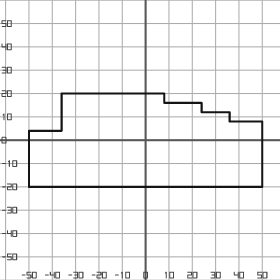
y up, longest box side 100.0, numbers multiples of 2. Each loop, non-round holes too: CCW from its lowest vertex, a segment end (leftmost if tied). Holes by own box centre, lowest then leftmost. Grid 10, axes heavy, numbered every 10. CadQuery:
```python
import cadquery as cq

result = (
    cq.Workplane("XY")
    .moveTo(-50.0, -20.0)
    .lineTo(50.0, -20.0)
    .lineTo(50.0, 8.0)
    .lineTo(36.0, 8.0)
    .lineTo(36.0, 12.0)
    .lineTo(24.0, 12.0)
    .lineTo(24.0, 16.0)
    .lineTo(8.0, 16.0)
    .lineTo(8.0, 20.0)
    .lineTo(-36.0, 20.0)
    .lineTo(-36.0, 4.0)
    .lineTo(-50.0, 4.0)
    .close()
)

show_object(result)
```